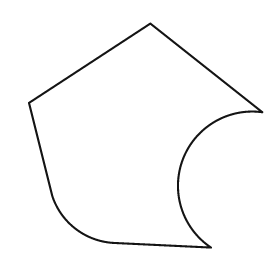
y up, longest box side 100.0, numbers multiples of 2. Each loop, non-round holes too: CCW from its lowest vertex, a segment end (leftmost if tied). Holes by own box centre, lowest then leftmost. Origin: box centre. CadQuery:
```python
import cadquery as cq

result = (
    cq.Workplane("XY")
    .moveTo(28.0, -48.0)
    .threePointArc((16.0, -10.0), (50.0, 10.0))
    .lineTo(2.0, 48.0)
    .lineTo(-50.0, 14.0)
    .lineTo(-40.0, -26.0)
    .threePointArc((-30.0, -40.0), (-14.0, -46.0))
    .close()
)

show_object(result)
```